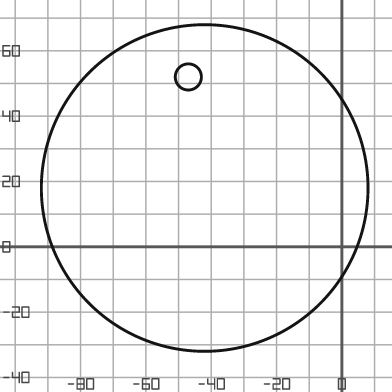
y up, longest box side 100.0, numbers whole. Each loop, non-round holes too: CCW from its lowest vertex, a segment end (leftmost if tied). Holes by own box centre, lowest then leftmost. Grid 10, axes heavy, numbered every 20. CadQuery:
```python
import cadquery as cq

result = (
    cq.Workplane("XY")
    .moveTo(-42.0, 18.0)
    .circle(50.0)
    .moveTo(-47.0, 52.0)
    .circle(4.0)
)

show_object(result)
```